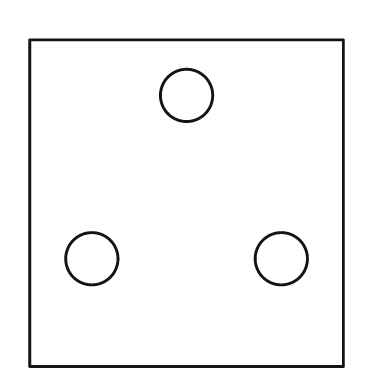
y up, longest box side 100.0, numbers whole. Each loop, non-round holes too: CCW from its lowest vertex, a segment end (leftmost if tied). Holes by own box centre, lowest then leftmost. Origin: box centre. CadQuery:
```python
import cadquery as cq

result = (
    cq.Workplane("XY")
    .moveTo(-48.0, -50.0)
    .lineTo(48.0, -50.0)
    .lineTo(48.0, 50.0)
    .lineTo(-48.0, 50.0)
    .close()
    .moveTo(-29.0, -17.0)
    .circle(8.0)
    .moveTo(29.0, -17.0)
    .circle(8.0)
    .moveTo(0.0, 33.0)
    .circle(8.0)
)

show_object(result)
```